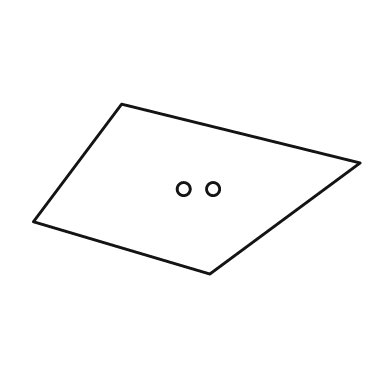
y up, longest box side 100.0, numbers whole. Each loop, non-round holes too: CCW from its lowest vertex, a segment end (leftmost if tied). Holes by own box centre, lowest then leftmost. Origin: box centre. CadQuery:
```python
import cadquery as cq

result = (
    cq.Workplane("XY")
    .moveTo(4.0, -26.0)
    .lineTo(50.0, 8.0)
    .lineTo(-23.0, 26.0)
    .lineTo(-50.0, -10.0)
    .close()
    .moveTo(-4.0, 0.0)
    .circle(2.0)
    .moveTo(5.0, 0.0)
    .circle(2.0)
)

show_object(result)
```